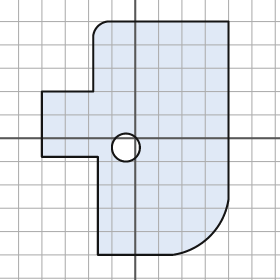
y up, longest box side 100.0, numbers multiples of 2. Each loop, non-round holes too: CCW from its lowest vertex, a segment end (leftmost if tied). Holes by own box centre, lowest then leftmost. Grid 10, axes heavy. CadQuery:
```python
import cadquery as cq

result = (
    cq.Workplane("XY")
    .moveTo(-16.0, -50.0)
    .lineTo(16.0, -50.0)
    .threePointArc((32.0, -42.0), (40.0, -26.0))
    .lineTo(40.0, 50.0)
    .lineTo(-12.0, 50.0)
    .threePointArc((-16.0, 48.0), (-18.0, 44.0))
    .lineTo(-18.0, 20.0)
    .lineTo(-40.0, 20.0)
    .lineTo(-40.0, -8.0)
    .lineTo(-16.0, -8.0)
    .close()
    .moveTo(-4.0, -4.0)
    .circle(6.0)
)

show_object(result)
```